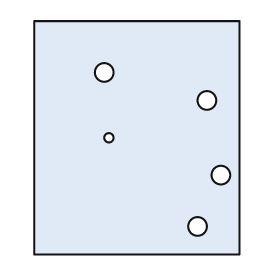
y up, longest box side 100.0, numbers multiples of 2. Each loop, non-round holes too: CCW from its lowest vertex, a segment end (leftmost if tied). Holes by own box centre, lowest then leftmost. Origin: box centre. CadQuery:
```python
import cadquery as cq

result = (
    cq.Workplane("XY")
    .moveTo(-44.0, -50.0)
    .lineTo(44.0, -50.0)
    .lineTo(44.0, 50.0)
    .lineTo(-44.0, 50.0)
    .close()
    .moveTo(26.0, -38.0)
    .circle(4.0)
    .moveTo(36.0, -16.0)
    .circle(4.0)
    .moveTo(-12.0, 0.0)
    .circle(2.0)
    .moveTo(30.0, 16.0)
    .circle(4.0)
    .moveTo(-14.0, 28.0)
    .circle(4.0)
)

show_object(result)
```